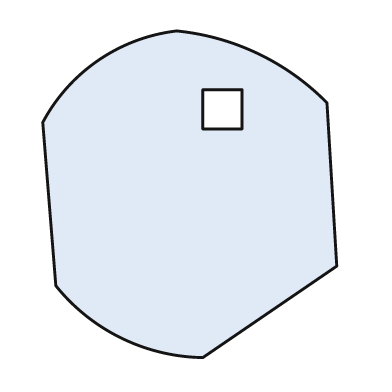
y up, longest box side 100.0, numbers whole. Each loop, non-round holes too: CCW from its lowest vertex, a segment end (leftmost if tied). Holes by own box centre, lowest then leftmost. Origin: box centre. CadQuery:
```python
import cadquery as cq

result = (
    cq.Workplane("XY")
    .moveTo(4.0, -50.0)
    .lineTo(45.0, -22.0)
    .lineTo(42.0, 28.0)
    .threePointArc((21.0, 43.0), (-4.0, 50.0))
    .threePointArc((-28.0, 41.0), (-45.0, 22.0))
    .lineTo(-41.0, -28.0)
    .threePointArc((-21.0, -44.0), (4.0, -50.0))
    .close()
    .moveTo(4.0, 20.0)
    .lineTo(16.0, 20.0)
    .lineTo(16.0, 32.0)
    .lineTo(4.0, 32.0)
    .close()
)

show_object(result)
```